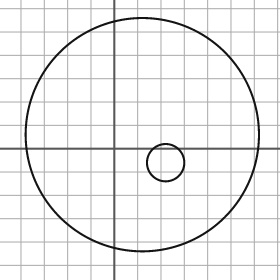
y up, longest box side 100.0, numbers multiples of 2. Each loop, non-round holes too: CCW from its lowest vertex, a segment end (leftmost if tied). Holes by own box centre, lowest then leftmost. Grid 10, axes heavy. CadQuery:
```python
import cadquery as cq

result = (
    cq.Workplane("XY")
    .moveTo(12.0, 6.0)
    .circle(50.0)
    .moveTo(22.0, -6.0)
    .circle(8.0)
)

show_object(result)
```